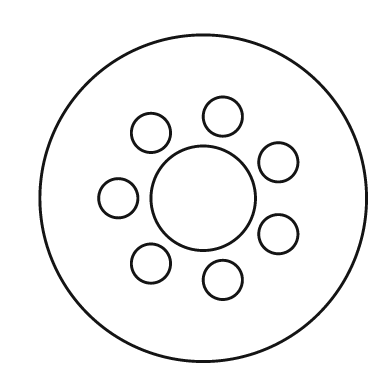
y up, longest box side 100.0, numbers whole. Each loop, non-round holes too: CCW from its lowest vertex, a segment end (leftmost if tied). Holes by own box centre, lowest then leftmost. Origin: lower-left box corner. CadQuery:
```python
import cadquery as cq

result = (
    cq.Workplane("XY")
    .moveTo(50.0, 50.0)
    .circle(50.0)
    .moveTo(56.0, 25.0)
    .circle(6.0)
    .moveTo(34.0, 30.0)
    .circle(6.0)
    .moveTo(73.0, 39.0)
    .circle(6.0)
    .moveTo(24.0, 50.0)
    .circle(6.0)
    .moveTo(50.0, 50.0)
    .circle(16.0)
    .moveTo(73.0, 61.0)
    .circle(6.0)
    .moveTo(34.0, 70.0)
    .circle(6.0)
    .moveTo(56.0, 75.0)
    .circle(6.0)
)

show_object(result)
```